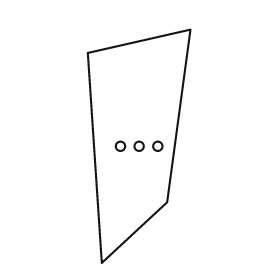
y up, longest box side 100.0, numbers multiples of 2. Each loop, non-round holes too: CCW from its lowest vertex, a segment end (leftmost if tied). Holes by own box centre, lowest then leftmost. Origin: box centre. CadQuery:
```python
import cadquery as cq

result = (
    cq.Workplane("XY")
    .moveTo(-16.0, -50.0)
    .lineTo(12.0, -24.0)
    .lineTo(22.0, 50.0)
    .lineTo(-22.0, 40.0)
    .close()
    .moveTo(-8.0, 0.0)
    .circle(2.0)
    .moveTo(0.0, 0.0)
    .circle(2.0)
    .moveTo(8.0, 0.0)
    .circle(2.0)
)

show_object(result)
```